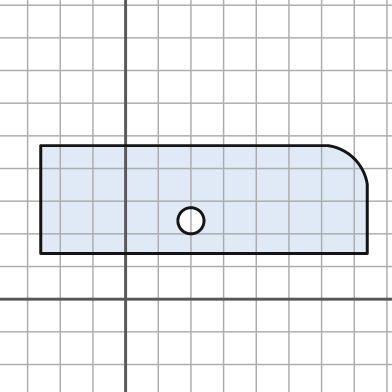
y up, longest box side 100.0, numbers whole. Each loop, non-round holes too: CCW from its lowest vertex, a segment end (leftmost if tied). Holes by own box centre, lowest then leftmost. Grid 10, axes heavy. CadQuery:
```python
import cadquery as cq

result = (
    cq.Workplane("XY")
    .moveTo(-26.0, 14.0)
    .lineTo(74.0, 14.0)
    .lineTo(74.0, 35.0)
    .threePointArc((70.0, 43.0), (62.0, 47.0))
    .lineTo(-26.0, 47.0)
    .close()
    .moveTo(20.0, 24.0)
    .circle(4.0)
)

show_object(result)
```